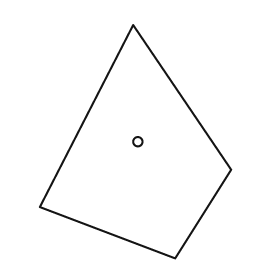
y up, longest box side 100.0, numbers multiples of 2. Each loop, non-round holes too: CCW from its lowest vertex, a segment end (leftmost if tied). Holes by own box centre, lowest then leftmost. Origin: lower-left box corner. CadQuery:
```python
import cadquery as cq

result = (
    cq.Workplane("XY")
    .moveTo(58.0, 0.0)
    .lineTo(82.0, 38.0)
    .lineTo(40.0, 100.0)
    .lineTo(0.0, 22.0)
    .close()
    .moveTo(42.0, 50.0)
    .circle(2.0)
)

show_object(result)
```